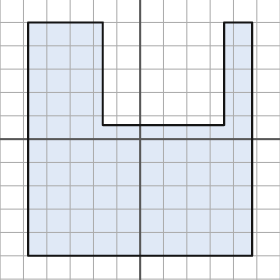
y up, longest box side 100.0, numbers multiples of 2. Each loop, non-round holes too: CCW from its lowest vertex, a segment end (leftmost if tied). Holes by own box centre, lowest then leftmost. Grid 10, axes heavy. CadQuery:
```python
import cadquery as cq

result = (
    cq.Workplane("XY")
    .moveTo(-48.0, -50.0)
    .lineTo(48.0, -50.0)
    .lineTo(48.0, 50.0)
    .lineTo(36.0, 50.0)
    .lineTo(36.0, 6.0)
    .lineTo(-16.0, 6.0)
    .lineTo(-16.0, 50.0)
    .lineTo(-48.0, 50.0)
    .close()
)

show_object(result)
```